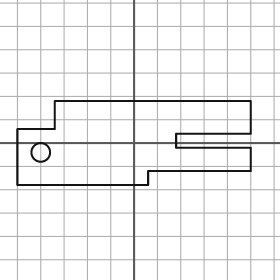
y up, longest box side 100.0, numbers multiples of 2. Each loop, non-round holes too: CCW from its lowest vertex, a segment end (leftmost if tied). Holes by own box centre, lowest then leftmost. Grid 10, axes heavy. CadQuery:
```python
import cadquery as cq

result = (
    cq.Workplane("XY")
    .moveTo(-50.0, -18.0)
    .lineTo(6.0, -18.0)
    .lineTo(6.0, -12.0)
    .lineTo(50.0, -12.0)
    .lineTo(50.0, -2.0)
    .lineTo(18.0, -2.0)
    .lineTo(18.0, 4.0)
    .lineTo(50.0, 4.0)
    .lineTo(50.0, 18.0)
    .lineTo(-34.0, 18.0)
    .lineTo(-34.0, 6.0)
    .lineTo(-50.0, 6.0)
    .close()
    .moveTo(-40.0, -4.0)
    .circle(4.0)
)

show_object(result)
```